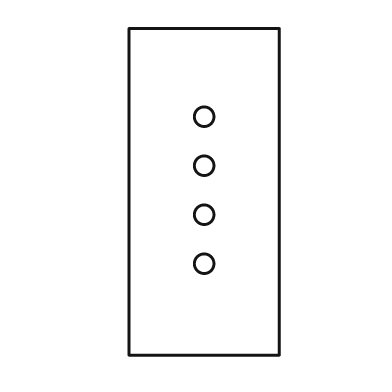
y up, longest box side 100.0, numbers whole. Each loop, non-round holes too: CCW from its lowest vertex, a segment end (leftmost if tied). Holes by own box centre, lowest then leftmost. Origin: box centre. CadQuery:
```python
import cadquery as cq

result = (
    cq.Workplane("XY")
    .moveTo(-23.0, -50.0)
    .lineTo(23.0, -50.0)
    .lineTo(23.0, 50.0)
    .lineTo(-23.0, 50.0)
    .close()
    .moveTo(0.0, -22.0)
    .circle(3.0)
    .moveTo(0.0, -7.0)
    .circle(3.0)
    .moveTo(0.0, 8.0)
    .circle(3.0)
    .moveTo(0.0, 23.0)
    .circle(3.0)
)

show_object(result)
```